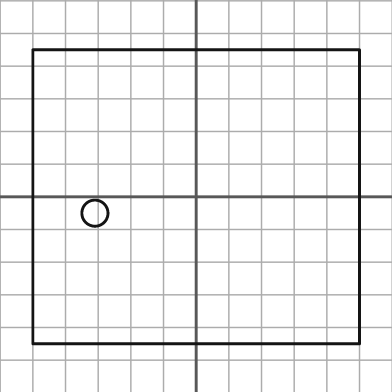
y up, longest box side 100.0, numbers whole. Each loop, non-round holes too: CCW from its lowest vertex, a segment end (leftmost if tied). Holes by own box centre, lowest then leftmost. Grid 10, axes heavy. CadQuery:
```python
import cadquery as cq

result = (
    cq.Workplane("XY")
    .moveTo(-50.0, -45.0)
    .lineTo(50.0, -45.0)
    .lineTo(50.0, 45.0)
    .lineTo(-50.0, 45.0)
    .close()
    .moveTo(-31.0, -5.0)
    .circle(4.0)
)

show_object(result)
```